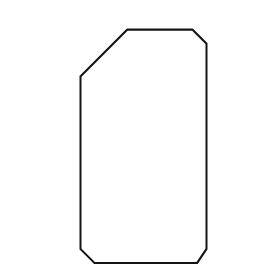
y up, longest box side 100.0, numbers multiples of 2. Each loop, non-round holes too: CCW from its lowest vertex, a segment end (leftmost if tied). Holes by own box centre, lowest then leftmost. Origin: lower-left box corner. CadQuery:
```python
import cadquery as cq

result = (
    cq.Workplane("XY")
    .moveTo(6.0, 0.0)
    .lineTo(50.0, 0.0)
    .lineTo(54.0, 6.0)
    .lineTo(54.0, 94.0)
    .lineTo(48.0, 100.0)
    .lineTo(20.0, 100.0)
    .lineTo(0.0, 80.0)
    .lineTo(0.0, 6.0)
    .close()
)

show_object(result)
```